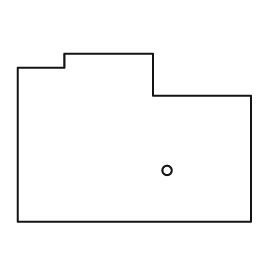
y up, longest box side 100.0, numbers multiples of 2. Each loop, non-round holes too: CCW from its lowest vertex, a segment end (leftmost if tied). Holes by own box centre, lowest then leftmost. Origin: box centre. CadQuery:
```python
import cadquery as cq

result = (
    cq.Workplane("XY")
    .moveTo(-50.0, -36.0)
    .lineTo(50.0, -36.0)
    .lineTo(50.0, 18.0)
    .lineTo(8.0, 18.0)
    .lineTo(8.0, 36.0)
    .lineTo(-30.0, 36.0)
    .lineTo(-30.0, 30.0)
    .lineTo(-50.0, 30.0)
    .close()
    .moveTo(14.0, -14.0)
    .circle(2.0)
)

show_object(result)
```